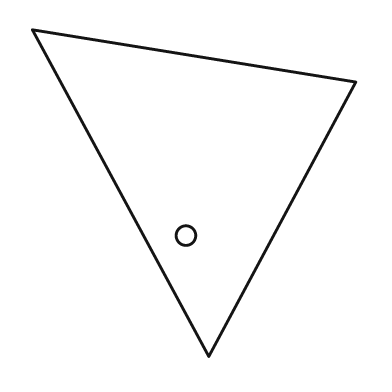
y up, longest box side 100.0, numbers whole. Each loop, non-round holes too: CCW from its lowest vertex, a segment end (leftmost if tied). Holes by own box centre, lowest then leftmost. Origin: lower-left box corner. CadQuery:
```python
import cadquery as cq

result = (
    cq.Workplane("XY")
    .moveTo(54.0, 0.0)
    .lineTo(99.0, 84.0)
    .lineTo(0.0, 100.0)
    .close()
    .moveTo(47.0, 37.0)
    .circle(3.0)
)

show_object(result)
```